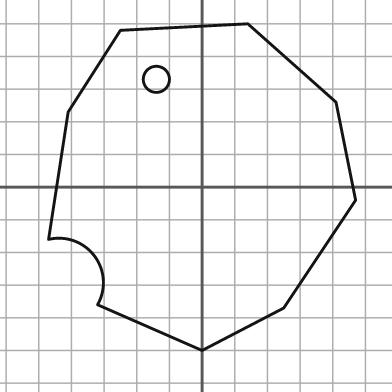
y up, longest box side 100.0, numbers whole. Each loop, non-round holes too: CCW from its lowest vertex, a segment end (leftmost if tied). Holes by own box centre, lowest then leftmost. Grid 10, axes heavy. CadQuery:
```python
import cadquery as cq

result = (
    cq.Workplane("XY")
    .moveTo(0.0, -50.0)
    .lineTo(25.0, -37.0)
    .lineTo(47.0, -4.0)
    .lineTo(41.0, 26.0)
    .lineTo(14.0, 50.0)
    .lineTo(-25.0, 48.0)
    .lineTo(-41.0, 23.0)
    .lineTo(-47.0, -16.0)
    .threePointArc((-33.0, -21.0), (-32.0, -36.0))
    .close()
    .moveTo(-14.0, 33.0)
    .circle(4.0)
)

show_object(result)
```